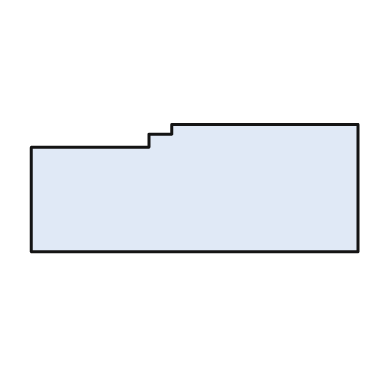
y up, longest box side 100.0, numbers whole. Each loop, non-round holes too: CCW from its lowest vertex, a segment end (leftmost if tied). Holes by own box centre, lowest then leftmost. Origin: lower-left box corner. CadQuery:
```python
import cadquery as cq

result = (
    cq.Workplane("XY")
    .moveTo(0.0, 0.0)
    .lineTo(100.0, 0.0)
    .lineTo(100.0, 39.0)
    .lineTo(43.0, 39.0)
    .lineTo(43.0, 36.0)
    .lineTo(36.0, 36.0)
    .lineTo(36.0, 32.0)
    .lineTo(0.0, 32.0)
    .close()
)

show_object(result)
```